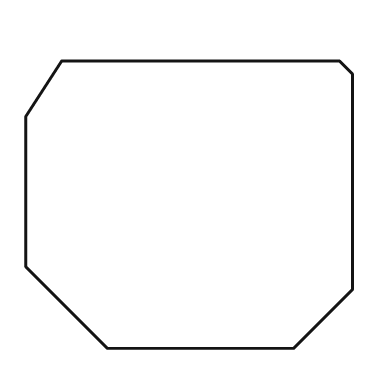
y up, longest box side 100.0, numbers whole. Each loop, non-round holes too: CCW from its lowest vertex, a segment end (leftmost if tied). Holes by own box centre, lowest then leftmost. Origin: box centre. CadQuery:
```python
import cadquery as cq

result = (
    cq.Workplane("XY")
    .moveTo(-25.0, -44.0)
    .lineTo(32.0, -44.0)
    .lineTo(50.0, -26.0)
    .lineTo(50.0, 40.0)
    .lineTo(46.0, 44.0)
    .lineTo(-39.0, 44.0)
    .lineTo(-50.0, 27.0)
    .lineTo(-50.0, -19.0)
    .close()
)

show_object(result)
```